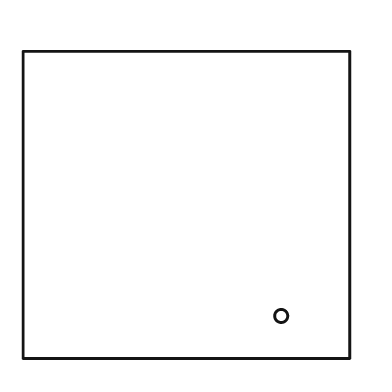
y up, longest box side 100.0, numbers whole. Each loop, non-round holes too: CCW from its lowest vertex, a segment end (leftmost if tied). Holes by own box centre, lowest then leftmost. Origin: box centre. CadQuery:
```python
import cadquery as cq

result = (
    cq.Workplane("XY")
    .moveTo(-50.0, -47.0)
    .lineTo(50.0, -47.0)
    .lineTo(50.0, 47.0)
    .lineTo(-50.0, 47.0)
    .close()
    .moveTo(29.0, -34.0)
    .circle(2.0)
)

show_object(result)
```